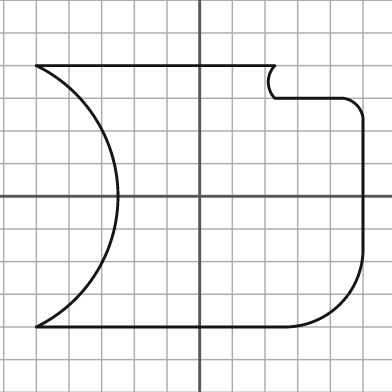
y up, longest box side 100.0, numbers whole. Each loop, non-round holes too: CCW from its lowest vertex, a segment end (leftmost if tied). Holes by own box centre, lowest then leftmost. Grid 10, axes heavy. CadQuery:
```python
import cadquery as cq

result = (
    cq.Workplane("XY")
    .moveTo(-50.0, -40.0)
    .lineTo(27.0, -40.0)
    .threePointArc((43.0, -33.0), (50.0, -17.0))
    .lineTo(50.0, 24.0)
    .threePointArc((48.0, 28.0), (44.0, 30.0))
    .lineTo(23.0, 30.0)
    .threePointArc((21.0, 35.0), (23.0, 40.0))
    .lineTo(-50.0, 40.0)
    .threePointArc((-25.0, 0.0), (-50.0, -40.0))
    .close()
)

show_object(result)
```